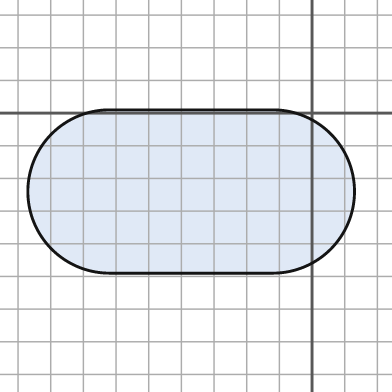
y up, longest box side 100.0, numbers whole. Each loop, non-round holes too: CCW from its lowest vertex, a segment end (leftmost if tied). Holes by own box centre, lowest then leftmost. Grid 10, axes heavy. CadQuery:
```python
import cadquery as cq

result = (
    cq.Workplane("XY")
    .moveTo(-62.0, -49.0)
    .lineTo(-12.0, -49.0)
    .threePointArc((13.0, -24.0), (-12.0, 1.0))
    .lineTo(-62.0, 1.0)
    .threePointArc((-87.0, -24.0), (-62.0, -49.0))
    .close()
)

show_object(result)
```